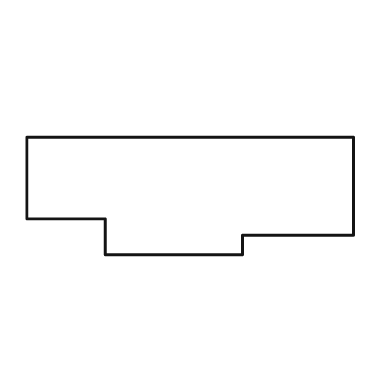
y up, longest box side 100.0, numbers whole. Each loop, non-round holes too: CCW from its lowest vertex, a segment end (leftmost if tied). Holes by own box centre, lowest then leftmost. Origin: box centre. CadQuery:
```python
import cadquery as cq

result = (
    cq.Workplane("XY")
    .moveTo(-26.0, -18.0)
    .lineTo(16.0, -18.0)
    .lineTo(16.0, -12.0)
    .lineTo(50.0, -12.0)
    .lineTo(50.0, 18.0)
    .lineTo(-50.0, 18.0)
    .lineTo(-50.0, -7.0)
    .lineTo(-26.0, -7.0)
    .close()
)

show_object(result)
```